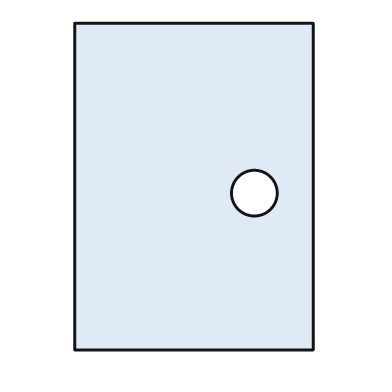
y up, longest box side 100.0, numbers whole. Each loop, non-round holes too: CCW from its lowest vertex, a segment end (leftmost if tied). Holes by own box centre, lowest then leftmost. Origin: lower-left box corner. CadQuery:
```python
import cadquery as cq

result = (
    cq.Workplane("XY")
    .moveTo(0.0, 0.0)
    .lineTo(73.0, 0.0)
    .lineTo(73.0, 100.0)
    .lineTo(0.0, 100.0)
    .close()
    .moveTo(55.0, 48.0)
    .circle(7.0)
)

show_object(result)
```